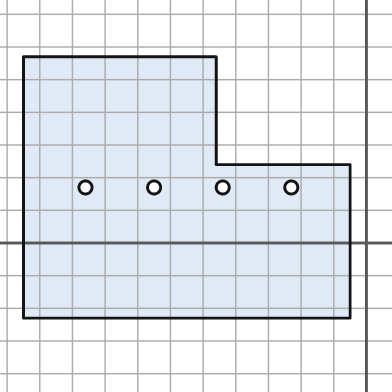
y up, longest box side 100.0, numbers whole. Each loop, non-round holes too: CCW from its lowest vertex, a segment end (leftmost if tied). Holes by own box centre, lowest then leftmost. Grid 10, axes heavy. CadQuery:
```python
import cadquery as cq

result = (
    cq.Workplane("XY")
    .moveTo(-105.0, -23.0)
    .lineTo(-5.0, -23.0)
    .lineTo(-5.0, 24.0)
    .lineTo(-46.0, 24.0)
    .lineTo(-46.0, 57.0)
    .lineTo(-105.0, 57.0)
    .close()
    .moveTo(-86.0, 17.0)
    .circle(2.0)
    .moveTo(-65.0, 17.0)
    .circle(2.0)
    .moveTo(-44.0, 17.0)
    .circle(2.0)
    .moveTo(-23.0, 17.0)
    .circle(2.0)
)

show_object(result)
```